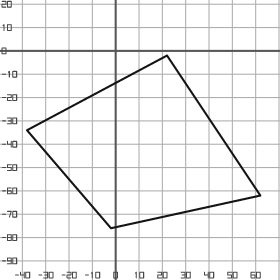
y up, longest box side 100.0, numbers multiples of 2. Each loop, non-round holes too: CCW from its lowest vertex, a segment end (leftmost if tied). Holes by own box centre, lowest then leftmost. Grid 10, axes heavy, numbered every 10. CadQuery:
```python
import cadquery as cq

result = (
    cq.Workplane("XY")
    .moveTo(-2.0, -76.0)
    .lineTo(62.0, -62.0)
    .lineTo(22.0, -2.0)
    .lineTo(-38.0, -34.0)
    .close()
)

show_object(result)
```